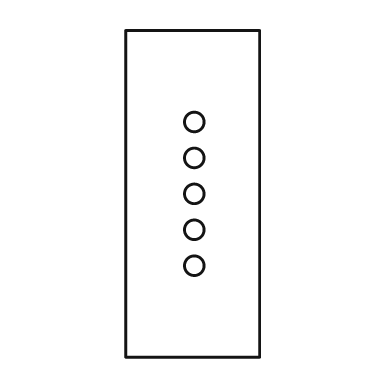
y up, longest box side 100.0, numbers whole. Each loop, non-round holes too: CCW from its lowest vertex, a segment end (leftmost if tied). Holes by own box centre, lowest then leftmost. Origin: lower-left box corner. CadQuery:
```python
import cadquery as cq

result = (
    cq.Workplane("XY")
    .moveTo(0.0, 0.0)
    .lineTo(41.0, 0.0)
    .lineTo(41.0, 100.0)
    .lineTo(0.0, 100.0)
    .close()
    .moveTo(21.0, 28.0)
    .circle(3.0)
    .moveTo(21.0, 39.0)
    .circle(3.0)
    .moveTo(21.0, 50.0)
    .circle(3.0)
    .moveTo(21.0, 61.0)
    .circle(3.0)
    .moveTo(21.0, 72.0)
    .circle(3.0)
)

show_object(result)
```